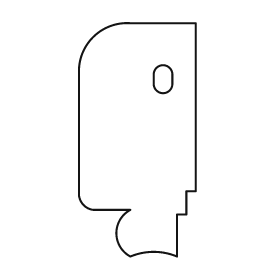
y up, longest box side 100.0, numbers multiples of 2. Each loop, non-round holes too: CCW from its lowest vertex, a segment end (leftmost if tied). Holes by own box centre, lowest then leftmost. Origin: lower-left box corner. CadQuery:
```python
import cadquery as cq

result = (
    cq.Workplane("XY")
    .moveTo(22.0, 0.0)
    .threePointArc((32.0, 2.0), (42.0, 0.0))
    .lineTo(42.0, 18.0)
    .lineTo(46.0, 18.0)
    .lineTo(46.0, 28.0)
    .lineTo(50.0, 28.0)
    .lineTo(50.0, 100.0)
    .lineTo(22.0, 100.0)
    .threePointArc((6.0, 94.0), (0.0, 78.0))
    .lineTo(0.0, 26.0)
    .threePointArc((2.0, 22.0), (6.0, 20.0))
    .lineTo(22.0, 20.0)
    .threePointArc((16.0, 10.0), (22.0, 0.0))
    .close()
    .moveTo(32.0, 74.0)
    .threePointArc((36.0, 70.0), (40.0, 74.0))
    .lineTo(40.0, 78.0)
    .threePointArc((36.0, 82.0), (32.0, 78.0))
    .close()
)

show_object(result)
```